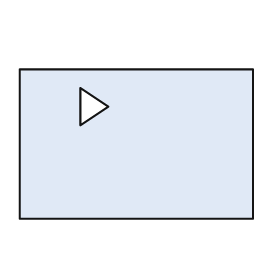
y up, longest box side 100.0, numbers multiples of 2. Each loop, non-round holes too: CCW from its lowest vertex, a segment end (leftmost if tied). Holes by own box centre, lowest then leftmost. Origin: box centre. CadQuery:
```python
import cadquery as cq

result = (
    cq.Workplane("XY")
    .moveTo(-50.0, -32.0)
    .lineTo(50.0, -32.0)
    .lineTo(50.0, 32.0)
    .lineTo(-50.0, 32.0)
    .close()
    .moveTo(-24.0, 8.0)
    .lineTo(-12.0, 16.0)
    .lineTo(-24.0, 24.0)
    .close()
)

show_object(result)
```